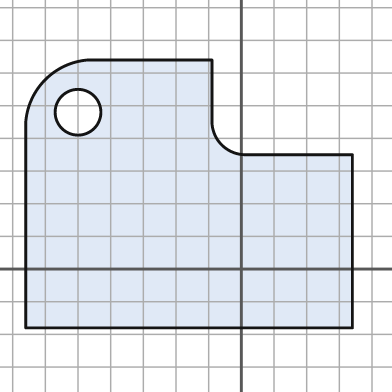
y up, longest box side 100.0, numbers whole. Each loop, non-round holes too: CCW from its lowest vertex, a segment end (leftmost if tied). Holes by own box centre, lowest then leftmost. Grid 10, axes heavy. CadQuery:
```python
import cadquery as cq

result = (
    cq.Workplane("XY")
    .moveTo(-66.0, -18.0)
    .lineTo(34.0, -18.0)
    .lineTo(34.0, 35.0)
    .lineTo(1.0, 35.0)
    .threePointArc((-6.0, 38.0), (-9.0, 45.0))
    .lineTo(-9.0, 64.0)
    .lineTo(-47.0, 64.0)
    .threePointArc((-60.0, 58.0), (-66.0, 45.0))
    .close()
    .moveTo(-50.0, 48.0)
    .circle(7.0)
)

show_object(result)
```